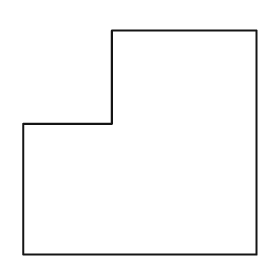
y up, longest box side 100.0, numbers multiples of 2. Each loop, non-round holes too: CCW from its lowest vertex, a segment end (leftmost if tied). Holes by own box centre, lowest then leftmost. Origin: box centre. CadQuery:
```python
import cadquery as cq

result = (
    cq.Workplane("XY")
    .moveTo(-50.0, -48.0)
    .lineTo(50.0, -48.0)
    .lineTo(50.0, 48.0)
    .lineTo(-12.0, 48.0)
    .lineTo(-12.0, 8.0)
    .lineTo(-50.0, 8.0)
    .close()
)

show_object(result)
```